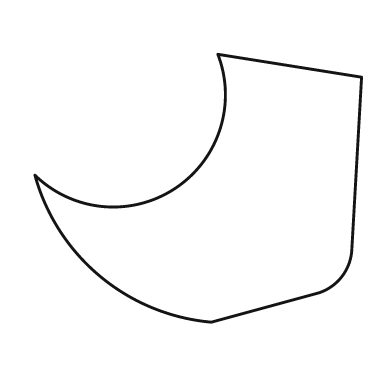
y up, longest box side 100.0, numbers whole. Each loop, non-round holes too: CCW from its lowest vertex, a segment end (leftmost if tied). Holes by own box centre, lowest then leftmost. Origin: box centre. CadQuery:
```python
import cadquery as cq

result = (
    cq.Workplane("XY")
    .moveTo(4.0, -41.0)
    .lineTo(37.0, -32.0)
    .threePointArc((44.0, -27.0), (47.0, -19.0))
    .lineTo(50.0, 34.0)
    .lineTo(6.0, 41.0)
    .threePointArc((-7.0, 0.0), (-50.0, 4.0))
    .threePointArc((-30.0, -27.0), (4.0, -41.0))
    .close()
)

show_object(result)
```